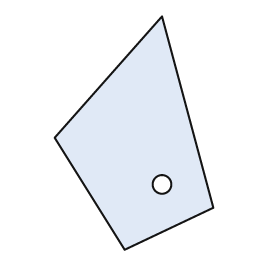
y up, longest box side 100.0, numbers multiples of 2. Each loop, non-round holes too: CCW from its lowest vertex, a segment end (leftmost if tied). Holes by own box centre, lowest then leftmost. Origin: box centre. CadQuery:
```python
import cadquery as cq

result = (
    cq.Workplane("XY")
    .moveTo(-4.0, -50.0)
    .lineTo(34.0, -32.0)
    .lineTo(12.0, 50.0)
    .lineTo(-34.0, -2.0)
    .close()
    .moveTo(12.0, -22.0)
    .circle(4.0)
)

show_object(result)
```